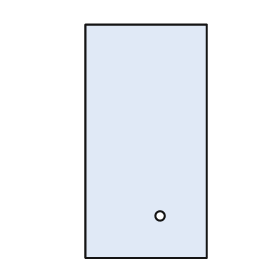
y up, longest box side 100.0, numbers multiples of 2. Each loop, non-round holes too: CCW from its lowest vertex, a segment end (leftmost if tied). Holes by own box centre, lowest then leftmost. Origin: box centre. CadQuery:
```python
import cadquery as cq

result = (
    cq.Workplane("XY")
    .moveTo(-26.0, -50.0)
    .lineTo(26.0, -50.0)
    .lineTo(26.0, 50.0)
    .lineTo(-26.0, 50.0)
    .close()
    .moveTo(6.0, -32.0)
    .circle(2.0)
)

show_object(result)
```